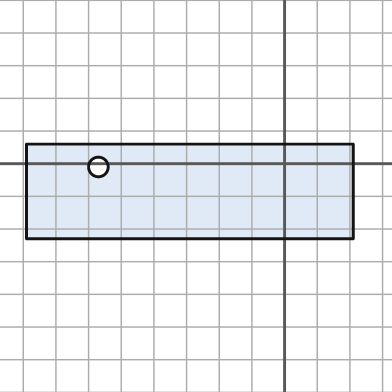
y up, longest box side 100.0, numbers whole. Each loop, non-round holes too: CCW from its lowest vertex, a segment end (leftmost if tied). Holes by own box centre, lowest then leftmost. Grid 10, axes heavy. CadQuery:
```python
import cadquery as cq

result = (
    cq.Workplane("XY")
    .moveTo(-79.0, -23.0)
    .lineTo(21.0, -23.0)
    .lineTo(21.0, 6.0)
    .lineTo(-79.0, 6.0)
    .close()
    .moveTo(-57.0, -1.0)
    .circle(3.0)
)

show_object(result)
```